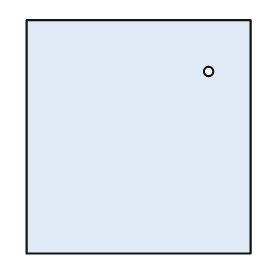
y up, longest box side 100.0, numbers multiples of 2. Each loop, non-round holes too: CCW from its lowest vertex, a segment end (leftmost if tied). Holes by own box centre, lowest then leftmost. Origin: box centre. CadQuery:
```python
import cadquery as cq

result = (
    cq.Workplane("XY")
    .moveTo(-48.0, -50.0)
    .lineTo(48.0, -50.0)
    .lineTo(48.0, 50.0)
    .lineTo(-48.0, 50.0)
    .close()
    .moveTo(30.0, 28.0)
    .circle(2.0)
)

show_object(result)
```